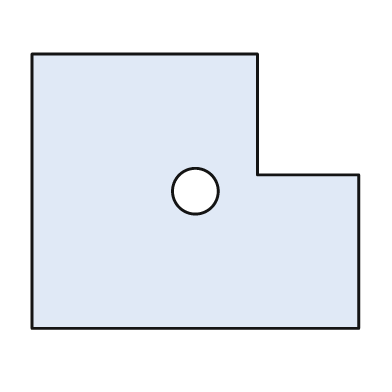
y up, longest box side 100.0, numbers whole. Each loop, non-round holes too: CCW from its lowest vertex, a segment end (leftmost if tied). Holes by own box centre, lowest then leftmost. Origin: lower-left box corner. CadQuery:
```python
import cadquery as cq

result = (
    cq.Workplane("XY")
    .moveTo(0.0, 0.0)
    .lineTo(100.0, 0.0)
    .lineTo(100.0, 47.0)
    .lineTo(69.0, 47.0)
    .lineTo(69.0, 84.0)
    .lineTo(0.0, 84.0)
    .close()
    .moveTo(50.0, 42.0)
    .circle(7.0)
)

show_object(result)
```